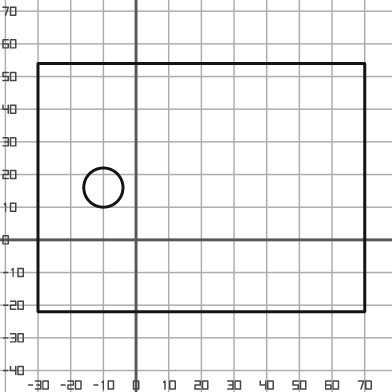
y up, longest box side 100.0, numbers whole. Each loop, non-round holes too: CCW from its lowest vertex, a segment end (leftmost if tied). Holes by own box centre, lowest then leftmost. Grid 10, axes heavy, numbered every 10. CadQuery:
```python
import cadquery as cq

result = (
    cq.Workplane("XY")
    .moveTo(-30.0, -22.0)
    .lineTo(70.0, -22.0)
    .lineTo(70.0, 54.0)
    .lineTo(-30.0, 54.0)
    .close()
    .moveTo(-10.0, 16.0)
    .circle(6.0)
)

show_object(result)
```